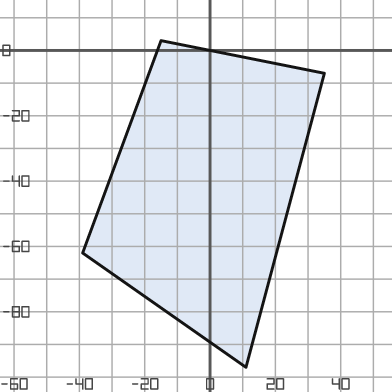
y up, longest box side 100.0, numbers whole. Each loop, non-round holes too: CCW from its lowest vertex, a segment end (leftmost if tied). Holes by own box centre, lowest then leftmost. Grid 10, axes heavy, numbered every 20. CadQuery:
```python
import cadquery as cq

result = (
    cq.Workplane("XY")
    .moveTo(11.0, -97.0)
    .lineTo(35.0, -7.0)
    .lineTo(-15.0, 3.0)
    .lineTo(-39.0, -62.0)
    .close()
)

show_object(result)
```